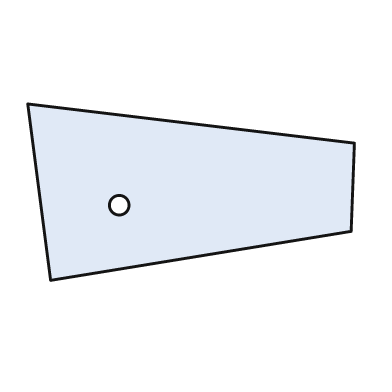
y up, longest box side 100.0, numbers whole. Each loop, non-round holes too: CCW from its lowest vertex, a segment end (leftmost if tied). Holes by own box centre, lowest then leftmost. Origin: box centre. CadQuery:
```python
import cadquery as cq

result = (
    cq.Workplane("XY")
    .moveTo(-43.0, -27.0)
    .lineTo(49.0, -12.0)
    .lineTo(50.0, 15.0)
    .lineTo(-50.0, 27.0)
    .close()
    .moveTo(-22.0, -4.0)
    .circle(3.0)
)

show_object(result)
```